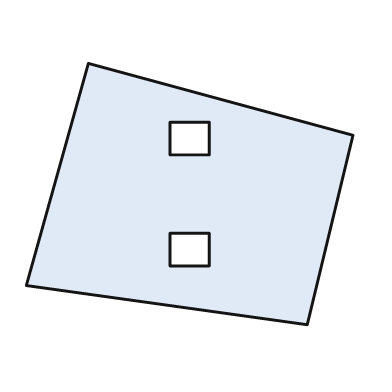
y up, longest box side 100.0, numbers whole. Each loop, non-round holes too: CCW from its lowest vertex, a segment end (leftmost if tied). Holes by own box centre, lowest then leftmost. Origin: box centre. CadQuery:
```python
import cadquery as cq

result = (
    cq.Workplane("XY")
    .moveTo(36.0, -40.0)
    .lineTo(50.0, 18.0)
    .lineTo(-31.0, 40.0)
    .lineTo(-50.0, -28.0)
    .close()
    .moveTo(-6.0, -22.0)
    .lineTo(6.0, -22.0)
    .lineTo(6.0, -12.0)
    .lineTo(-6.0, -12.0)
    .close()
    .moveTo(-6.0, 12.0)
    .lineTo(6.0, 12.0)
    .lineTo(6.0, 22.0)
    .lineTo(-6.0, 22.0)
    .close()
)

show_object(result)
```